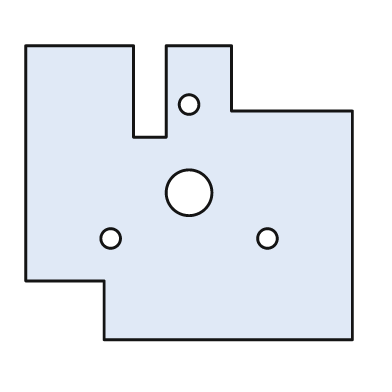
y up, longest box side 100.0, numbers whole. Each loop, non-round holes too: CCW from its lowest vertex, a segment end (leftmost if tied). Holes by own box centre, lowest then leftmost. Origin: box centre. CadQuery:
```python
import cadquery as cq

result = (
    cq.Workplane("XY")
    .moveTo(-26.0, -45.0)
    .lineTo(50.0, -45.0)
    .lineTo(50.0, 25.0)
    .lineTo(13.0, 25.0)
    .lineTo(13.0, 45.0)
    .lineTo(-7.0, 45.0)
    .lineTo(-7.0, 17.0)
    .lineTo(-17.0, 17.0)
    .lineTo(-17.0, 45.0)
    .lineTo(-50.0, 45.0)
    .lineTo(-50.0, -27.0)
    .lineTo(-26.0, -27.0)
    .close()
    .moveTo(-24.0, -14.0)
    .circle(3.0)
    .moveTo(24.0, -14.0)
    .circle(3.0)
    .moveTo(0.0, 0.0)
    .circle(7.0)
    .moveTo(0.0, 27.0)
    .circle(3.0)
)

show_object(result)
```